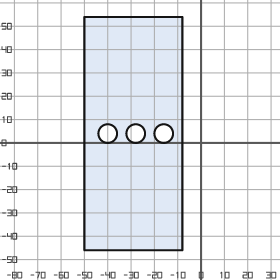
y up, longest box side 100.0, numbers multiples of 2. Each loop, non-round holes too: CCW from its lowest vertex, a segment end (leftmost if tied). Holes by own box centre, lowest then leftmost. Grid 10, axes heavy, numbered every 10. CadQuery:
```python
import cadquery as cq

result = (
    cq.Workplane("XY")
    .moveTo(-50.0, -46.0)
    .lineTo(-8.0, -46.0)
    .lineTo(-8.0, 54.0)
    .lineTo(-50.0, 54.0)
    .close()
    .moveTo(-40.0, 4.0)
    .circle(4.0)
    .moveTo(-28.0, 4.0)
    .circle(4.0)
    .moveTo(-16.0, 4.0)
    .circle(4.0)
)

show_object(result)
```